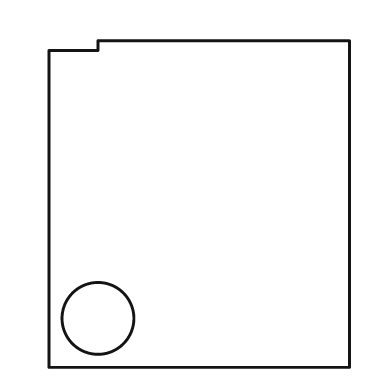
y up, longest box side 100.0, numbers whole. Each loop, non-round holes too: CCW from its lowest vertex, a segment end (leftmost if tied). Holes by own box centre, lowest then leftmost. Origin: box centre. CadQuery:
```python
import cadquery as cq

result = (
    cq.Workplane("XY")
    .moveTo(-46.0, -50.0)
    .lineTo(46.0, -50.0)
    .lineTo(46.0, 50.0)
    .lineTo(-31.0, 50.0)
    .lineTo(-31.0, 47.0)
    .lineTo(-46.0, 47.0)
    .close()
    .moveTo(-31.0, -35.0)
    .circle(11.0)
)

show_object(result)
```